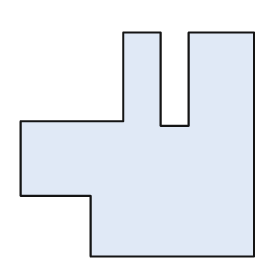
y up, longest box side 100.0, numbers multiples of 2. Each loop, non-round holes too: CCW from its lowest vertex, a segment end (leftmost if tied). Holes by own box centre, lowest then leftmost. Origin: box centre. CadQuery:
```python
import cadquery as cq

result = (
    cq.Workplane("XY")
    .moveTo(-20.0, -48.0)
    .lineTo(50.0, -48.0)
    .lineTo(50.0, 48.0)
    .lineTo(22.0, 48.0)
    .lineTo(22.0, 8.0)
    .lineTo(10.0, 8.0)
    .lineTo(10.0, 48.0)
    .lineTo(-6.0, 48.0)
    .lineTo(-6.0, 10.0)
    .lineTo(-50.0, 10.0)
    .lineTo(-50.0, -22.0)
    .lineTo(-20.0, -22.0)
    .close()
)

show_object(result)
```